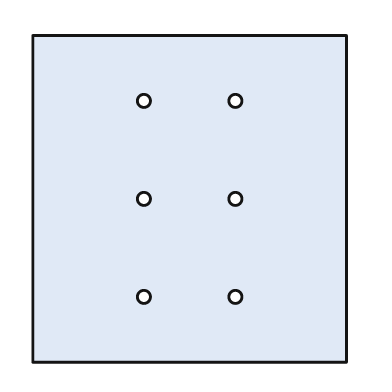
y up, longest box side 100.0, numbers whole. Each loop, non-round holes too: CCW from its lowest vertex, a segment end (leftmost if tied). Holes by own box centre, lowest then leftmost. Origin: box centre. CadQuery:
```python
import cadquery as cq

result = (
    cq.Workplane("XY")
    .moveTo(-48.0, -50.0)
    .lineTo(48.0, -50.0)
    .lineTo(48.0, 50.0)
    .lineTo(-48.0, 50.0)
    .close()
    .moveTo(-14.0, -30.0)
    .circle(2.0)
    .moveTo(14.0, -30.0)
    .circle(2.0)
    .moveTo(-14.0, 0.0)
    .circle(2.0)
    .moveTo(14.0, 0.0)
    .circle(2.0)
    .moveTo(-14.0, 30.0)
    .circle(2.0)
    .moveTo(14.0, 30.0)
    .circle(2.0)
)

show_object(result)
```